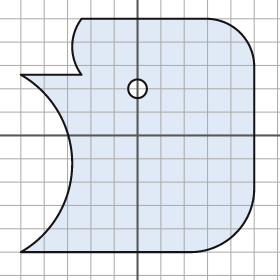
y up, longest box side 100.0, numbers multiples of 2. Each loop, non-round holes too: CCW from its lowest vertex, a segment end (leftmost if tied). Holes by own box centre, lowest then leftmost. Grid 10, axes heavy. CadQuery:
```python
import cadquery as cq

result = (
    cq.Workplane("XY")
    .moveTo(-50.0, -50.0)
    .lineTo(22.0, -50.0)
    .threePointArc((42.0, -42.0), (50.0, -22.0))
    .lineTo(50.0, 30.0)
    .threePointArc((44.0, 44.0), (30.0, 50.0))
    .lineTo(-24.0, 50.0)
    .threePointArc((-28.0, 38.0), (-24.0, 26.0))
    .lineTo(-50.0, 26.0)
    .threePointArc((-28.0, -12.0), (-50.0, -50.0))
    .close()
    .moveTo(0.0, 20.0)
    .circle(4.0)
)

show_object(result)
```